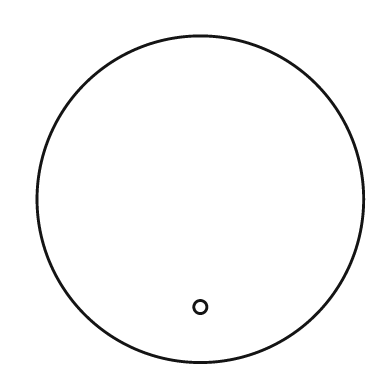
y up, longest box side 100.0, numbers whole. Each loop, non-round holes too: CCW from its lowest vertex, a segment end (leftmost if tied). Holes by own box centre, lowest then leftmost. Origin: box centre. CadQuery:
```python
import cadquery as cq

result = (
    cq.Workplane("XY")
    .moveTo(0.0, 0.0)
    .circle(50.0)
    .moveTo(0.0, -33.0)
    .circle(2.0)
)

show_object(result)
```